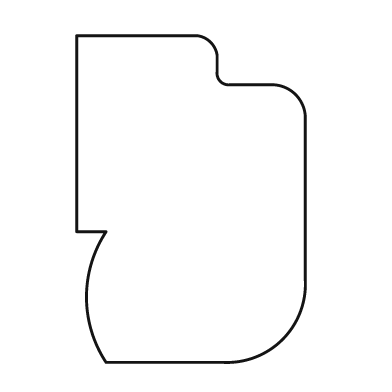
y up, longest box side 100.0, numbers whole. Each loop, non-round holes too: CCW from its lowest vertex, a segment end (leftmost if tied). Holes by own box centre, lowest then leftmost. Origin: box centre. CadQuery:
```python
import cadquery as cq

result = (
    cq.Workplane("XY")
    .moveTo(-26.0, -50.0)
    .lineTo(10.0, -50.0)
    .threePointArc((28.0, -43.0), (35.0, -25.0))
    .lineTo(35.0, 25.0)
    .threePointArc((32.0, 32.0), (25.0, 35.0))
    .lineTo(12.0, 35.0)
    .threePointArc((9.0, 36.0), (8.0, 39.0))
    .lineTo(8.0, 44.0)
    .threePointArc((6.0, 48.0), (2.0, 50.0))
    .lineTo(-35.0, 50.0)
    .lineTo(-35.0, -10.0)
    .lineTo(-26.0, -10.0)
    .threePointArc((-32.0, -30.0), (-26.0, -50.0))
    .close()
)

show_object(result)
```